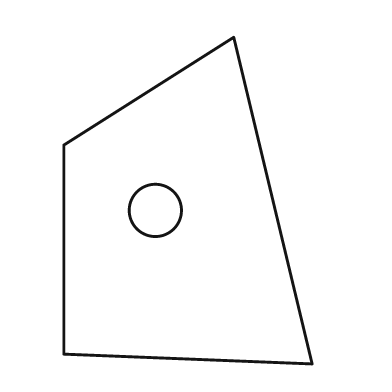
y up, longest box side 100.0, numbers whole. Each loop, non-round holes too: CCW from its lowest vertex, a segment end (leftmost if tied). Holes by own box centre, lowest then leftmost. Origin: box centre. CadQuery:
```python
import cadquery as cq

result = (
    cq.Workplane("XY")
    .moveTo(38.0, -50.0)
    .lineTo(14.0, 50.0)
    .lineTo(-38.0, 17.0)
    .lineTo(-38.0, -47.0)
    .close()
    .moveTo(-10.0, -3.0)
    .circle(8.0)
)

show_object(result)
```